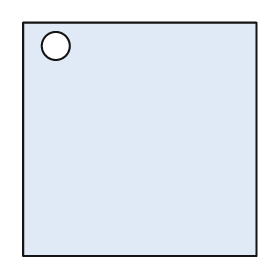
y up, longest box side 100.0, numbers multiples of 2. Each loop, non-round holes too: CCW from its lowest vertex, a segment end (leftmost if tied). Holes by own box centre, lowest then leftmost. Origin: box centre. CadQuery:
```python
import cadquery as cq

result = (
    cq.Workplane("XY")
    .moveTo(-50.0, -50.0)
    .lineTo(50.0, -50.0)
    .lineTo(50.0, 50.0)
    .lineTo(-50.0, 50.0)
    .close()
    .moveTo(-36.0, 40.0)
    .circle(6.0)
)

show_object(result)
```